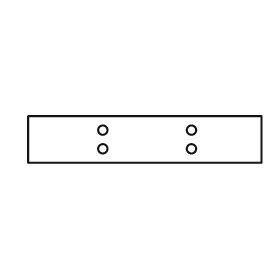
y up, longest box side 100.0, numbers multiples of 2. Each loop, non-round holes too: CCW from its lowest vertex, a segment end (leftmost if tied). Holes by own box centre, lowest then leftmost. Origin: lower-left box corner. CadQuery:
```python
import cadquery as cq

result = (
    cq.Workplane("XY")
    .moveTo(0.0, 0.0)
    .lineTo(100.0, 0.0)
    .lineTo(100.0, 20.0)
    .lineTo(0.0, 20.0)
    .close()
    .moveTo(32.0, 6.0)
    .circle(2.0)
    .moveTo(70.0, 6.0)
    .circle(2.0)
    .moveTo(32.0, 14.0)
    .circle(2.0)
    .moveTo(70.0, 14.0)
    .circle(2.0)
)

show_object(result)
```